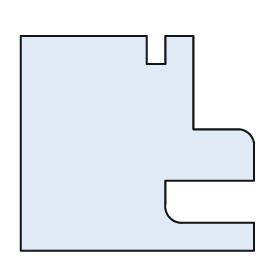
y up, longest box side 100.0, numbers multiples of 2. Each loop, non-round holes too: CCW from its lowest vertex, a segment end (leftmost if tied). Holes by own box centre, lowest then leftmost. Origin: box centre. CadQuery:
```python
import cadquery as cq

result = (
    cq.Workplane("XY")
    .moveTo(-50.0, -46.0)
    .lineTo(50.0, -46.0)
    .lineTo(50.0, -34.0)
    .lineTo(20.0, -34.0)
    .threePointArc((14.0, -32.0), (12.0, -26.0))
    .lineTo(12.0, -16.0)
    .lineTo(50.0, -16.0)
    .lineTo(50.0, 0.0)
    .threePointArc((48.0, 4.0), (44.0, 6.0))
    .lineTo(24.0, 6.0)
    .lineTo(24.0, 46.0)
    .lineTo(12.0, 46.0)
    .lineTo(12.0, 34.0)
    .lineTo(4.0, 34.0)
    .lineTo(4.0, 46.0)
    .lineTo(-50.0, 46.0)
    .close()
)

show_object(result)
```